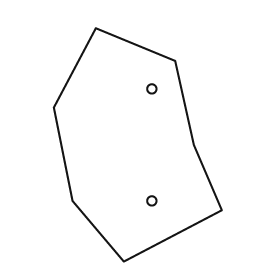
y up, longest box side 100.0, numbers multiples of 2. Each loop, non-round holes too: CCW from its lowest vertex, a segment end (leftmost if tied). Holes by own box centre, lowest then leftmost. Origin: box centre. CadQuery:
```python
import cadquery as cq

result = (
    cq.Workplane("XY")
    .moveTo(-6.0, -50.0)
    .lineTo(36.0, -28.0)
    .lineTo(24.0, 0.0)
    .lineTo(16.0, 36.0)
    .lineTo(-18.0, 50.0)
    .lineTo(-36.0, 16.0)
    .lineTo(-28.0, -24.0)
    .close()
    .moveTo(6.0, -24.0)
    .circle(2.0)
    .moveTo(6.0, 24.0)
    .circle(2.0)
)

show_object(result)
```